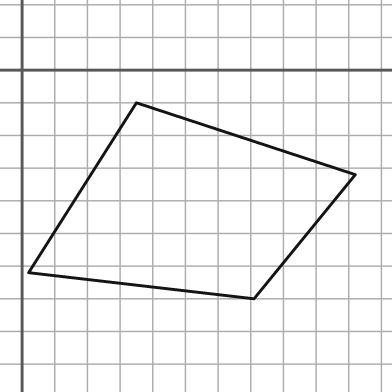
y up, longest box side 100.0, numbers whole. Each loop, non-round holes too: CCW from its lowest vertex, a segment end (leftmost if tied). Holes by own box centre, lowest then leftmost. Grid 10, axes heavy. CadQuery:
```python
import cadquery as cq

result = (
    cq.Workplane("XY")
    .moveTo(71.0, -70.0)
    .lineTo(102.0, -32.0)
    .lineTo(35.0, -10.0)
    .lineTo(2.0, -62.0)
    .close()
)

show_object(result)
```